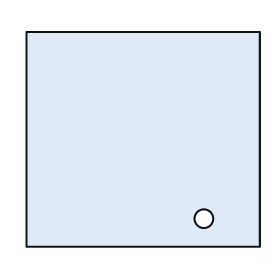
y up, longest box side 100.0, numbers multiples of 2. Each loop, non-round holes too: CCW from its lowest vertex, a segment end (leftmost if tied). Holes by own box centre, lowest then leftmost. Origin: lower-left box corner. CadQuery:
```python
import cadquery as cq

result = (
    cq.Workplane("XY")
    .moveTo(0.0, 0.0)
    .lineTo(100.0, 0.0)
    .lineTo(100.0, 92.0)
    .lineTo(0.0, 92.0)
    .close()
    .moveTo(76.0, 12.0)
    .circle(4.0)
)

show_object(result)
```